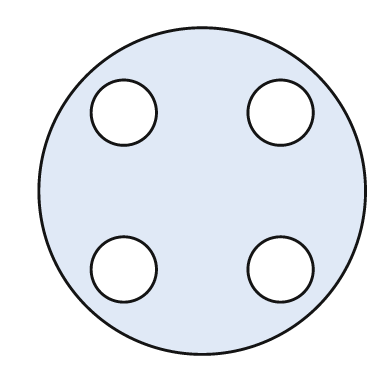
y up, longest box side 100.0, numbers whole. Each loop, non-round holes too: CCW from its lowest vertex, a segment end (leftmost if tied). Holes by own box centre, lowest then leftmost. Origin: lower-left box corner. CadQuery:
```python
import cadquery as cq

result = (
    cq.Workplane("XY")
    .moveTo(50.0, 50.0)
    .circle(50.0)
    .moveTo(26.0, 26.0)
    .circle(10.0)
    .moveTo(74.0, 26.0)
    .circle(10.0)
    .moveTo(26.0, 74.0)
    .circle(10.0)
    .moveTo(74.0, 74.0)
    .circle(10.0)
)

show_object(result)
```